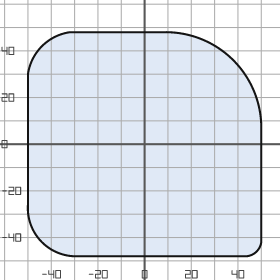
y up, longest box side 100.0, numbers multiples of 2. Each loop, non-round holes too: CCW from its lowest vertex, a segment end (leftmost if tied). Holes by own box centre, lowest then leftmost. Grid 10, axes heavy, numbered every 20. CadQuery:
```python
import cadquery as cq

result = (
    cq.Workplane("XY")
    .moveTo(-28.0, -48.0)
    .lineTo(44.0, -48.0)
    .threePointArc((48.0, -46.0), (50.0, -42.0))
    .lineTo(50.0, 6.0)
    .threePointArc((38.0, 36.0), (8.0, 48.0))
    .lineTo(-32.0, 48.0)
    .threePointArc((-44.0, 42.0), (-50.0, 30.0))
    .lineTo(-50.0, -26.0)
    .threePointArc((-44.0, -42.0), (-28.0, -48.0))
    .close()
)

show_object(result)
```